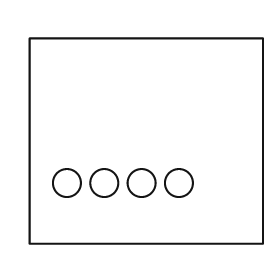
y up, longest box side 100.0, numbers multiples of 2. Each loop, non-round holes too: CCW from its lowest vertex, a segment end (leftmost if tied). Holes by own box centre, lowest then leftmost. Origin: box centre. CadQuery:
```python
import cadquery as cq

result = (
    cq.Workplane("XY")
    .moveTo(-50.0, -44.0)
    .lineTo(50.0, -44.0)
    .lineTo(50.0, 44.0)
    .lineTo(-50.0, 44.0)
    .close()
    .moveTo(-34.0, -18.0)
    .circle(6.0)
    .moveTo(-18.0, -18.0)
    .circle(6.0)
    .moveTo(-2.0, -18.0)
    .circle(6.0)
    .moveTo(14.0, -18.0)
    .circle(6.0)
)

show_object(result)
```